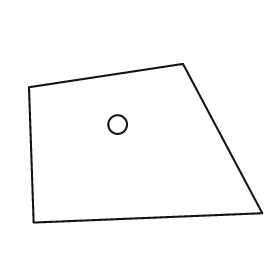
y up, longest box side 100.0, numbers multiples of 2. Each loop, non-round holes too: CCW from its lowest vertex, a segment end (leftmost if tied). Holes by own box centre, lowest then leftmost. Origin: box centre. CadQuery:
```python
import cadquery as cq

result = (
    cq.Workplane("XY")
    .moveTo(-48.0, -34.0)
    .lineTo(50.0, -30.0)
    .lineTo(16.0, 34.0)
    .lineTo(-50.0, 24.0)
    .close()
    .moveTo(-12.0, 8.0)
    .circle(4.0)
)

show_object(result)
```